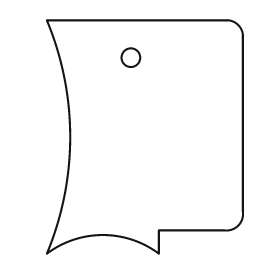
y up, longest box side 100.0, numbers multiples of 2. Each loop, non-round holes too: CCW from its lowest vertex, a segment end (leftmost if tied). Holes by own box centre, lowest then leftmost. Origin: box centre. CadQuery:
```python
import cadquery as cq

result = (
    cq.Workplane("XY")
    .moveTo(-42.0, -50.0)
    .threePointArc((-18.0, -42.0), (6.0, -50.0))
    .lineTo(6.0, -40.0)
    .lineTo(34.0, -40.0)
    .threePointArc((40.0, -38.0), (42.0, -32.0))
    .lineTo(42.0, 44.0)
    .threePointArc((40.0, 48.0), (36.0, 50.0))
    .lineTo(-42.0, 50.0)
    .threePointArc((-32.0, 0.0), (-42.0, -50.0))
    .close()
    .moveTo(-6.0, 34.0)
    .circle(4.0)
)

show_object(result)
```